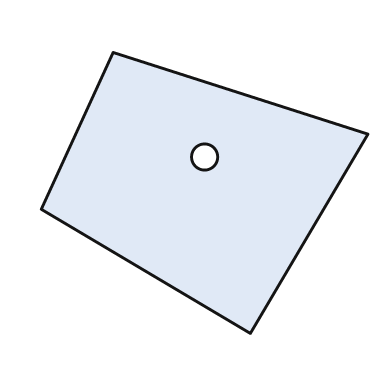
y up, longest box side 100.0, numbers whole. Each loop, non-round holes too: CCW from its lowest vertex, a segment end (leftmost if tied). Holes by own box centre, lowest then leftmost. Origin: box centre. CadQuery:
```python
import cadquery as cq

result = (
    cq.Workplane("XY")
    .moveTo(14.0, -43.0)
    .lineTo(50.0, 18.0)
    .lineTo(-28.0, 43.0)
    .lineTo(-50.0, -5.0)
    .close()
    .moveTo(0.0, 11.0)
    .circle(4.0)
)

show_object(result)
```